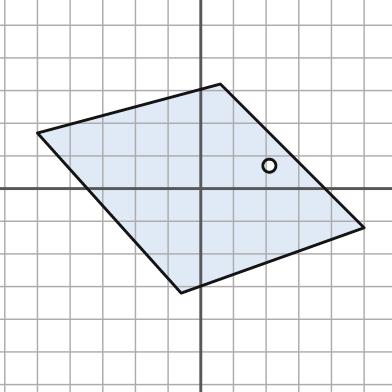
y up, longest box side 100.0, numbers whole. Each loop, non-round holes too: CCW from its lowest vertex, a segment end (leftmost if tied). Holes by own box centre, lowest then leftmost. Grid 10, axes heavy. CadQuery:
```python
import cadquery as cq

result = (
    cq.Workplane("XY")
    .moveTo(-6.0, -32.0)
    .lineTo(50.0, -12.0)
    .lineTo(6.0, 32.0)
    .lineTo(-50.0, 17.0)
    .close()
    .moveTo(21.0, 7.0)
    .circle(2.0)
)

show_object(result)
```